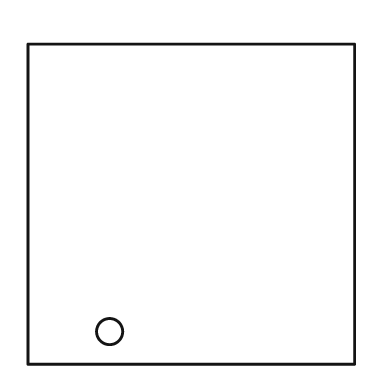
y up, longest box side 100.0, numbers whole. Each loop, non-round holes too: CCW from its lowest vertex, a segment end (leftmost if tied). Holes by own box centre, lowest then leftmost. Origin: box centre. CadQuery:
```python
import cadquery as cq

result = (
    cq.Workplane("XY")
    .moveTo(-50.0, -49.0)
    .lineTo(50.0, -49.0)
    .lineTo(50.0, 49.0)
    .lineTo(-50.0, 49.0)
    .close()
    .moveTo(-25.0, -39.0)
    .circle(4.0)
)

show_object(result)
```